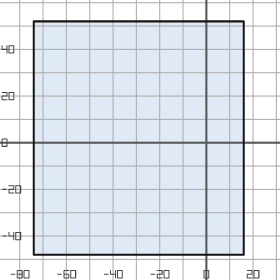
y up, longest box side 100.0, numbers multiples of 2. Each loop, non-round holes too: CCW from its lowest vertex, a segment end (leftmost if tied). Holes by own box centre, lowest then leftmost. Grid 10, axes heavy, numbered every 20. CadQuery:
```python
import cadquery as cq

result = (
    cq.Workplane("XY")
    .moveTo(-74.0, -48.0)
    .lineTo(16.0, -48.0)
    .lineTo(16.0, 52.0)
    .lineTo(-74.0, 52.0)
    .close()
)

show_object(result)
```